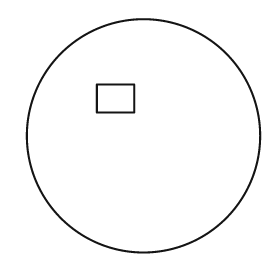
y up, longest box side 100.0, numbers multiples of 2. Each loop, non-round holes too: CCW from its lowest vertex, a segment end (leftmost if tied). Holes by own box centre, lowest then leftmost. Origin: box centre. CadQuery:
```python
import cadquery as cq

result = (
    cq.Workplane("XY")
    .moveTo(0.0, 0.0)
    .circle(50.0)
    .moveTo(-20.0, 10.0)
    .lineTo(-4.0, 10.0)
    .lineTo(-4.0, 22.0)
    .lineTo(-20.0, 22.0)
    .close()
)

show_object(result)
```